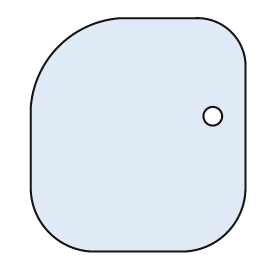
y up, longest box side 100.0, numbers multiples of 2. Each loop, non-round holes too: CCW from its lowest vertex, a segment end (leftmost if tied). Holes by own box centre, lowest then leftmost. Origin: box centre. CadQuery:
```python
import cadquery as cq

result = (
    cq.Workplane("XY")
    .moveTo(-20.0, -50.0)
    .lineTo(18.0, -50.0)
    .threePointArc((38.0, -42.0), (46.0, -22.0))
    .lineTo(46.0, 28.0)
    .threePointArc((40.0, 44.0), (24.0, 50.0))
    .lineTo(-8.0, 50.0)
    .threePointArc((-34.0, 38.0), (-46.0, 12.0))
    .lineTo(-46.0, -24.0)
    .threePointArc((-38.0, -42.0), (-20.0, -50.0))
    .close()
    .moveTo(32.0, 8.0)
    .circle(4.0)
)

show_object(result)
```